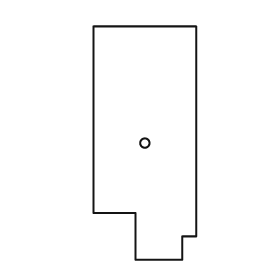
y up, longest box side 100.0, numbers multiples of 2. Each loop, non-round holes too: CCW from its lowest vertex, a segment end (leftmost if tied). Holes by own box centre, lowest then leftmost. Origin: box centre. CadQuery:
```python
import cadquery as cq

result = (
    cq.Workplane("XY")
    .moveTo(-4.0, -50.0)
    .lineTo(16.0, -50.0)
    .lineTo(16.0, -40.0)
    .lineTo(22.0, -40.0)
    .lineTo(22.0, 50.0)
    .lineTo(-22.0, 50.0)
    .lineTo(-22.0, -30.0)
    .lineTo(-4.0, -30.0)
    .close()
    .moveTo(0.0, 0.0)
    .circle(2.0)
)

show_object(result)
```